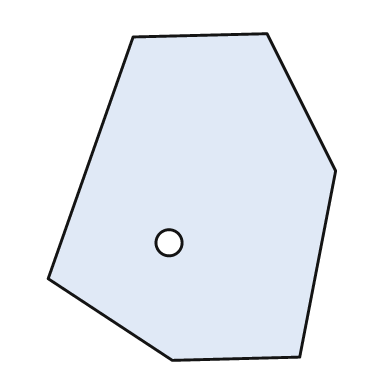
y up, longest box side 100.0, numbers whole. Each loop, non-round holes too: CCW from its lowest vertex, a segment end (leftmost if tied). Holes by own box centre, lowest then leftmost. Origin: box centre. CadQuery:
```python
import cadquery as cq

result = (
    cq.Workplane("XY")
    .moveTo(-6.0, -50.0)
    .lineTo(33.0, -49.0)
    .lineTo(44.0, 8.0)
    .lineTo(23.0, 50.0)
    .lineTo(-18.0, 49.0)
    .lineTo(-44.0, -25.0)
    .close()
    .moveTo(-7.0, -14.0)
    .circle(4.0)
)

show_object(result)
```